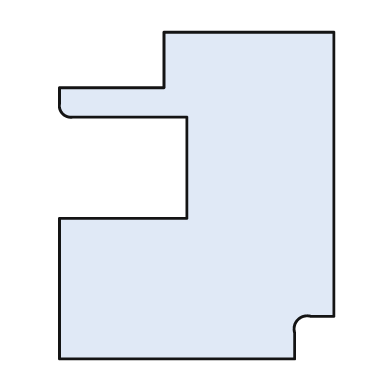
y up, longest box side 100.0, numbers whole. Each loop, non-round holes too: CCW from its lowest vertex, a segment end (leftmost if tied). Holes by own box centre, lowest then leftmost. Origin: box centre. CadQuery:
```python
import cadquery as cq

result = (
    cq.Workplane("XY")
    .moveTo(-42.0, -50.0)
    .lineTo(30.0, -50.0)
    .lineTo(30.0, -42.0)
    .threePointArc((31.0, -38.0), (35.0, -37.0))
    .lineTo(42.0, -37.0)
    .lineTo(42.0, 50.0)
    .lineTo(-10.0, 50.0)
    .lineTo(-10.0, 33.0)
    .lineTo(-42.0, 33.0)
    .lineTo(-42.0, 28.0)
    .threePointArc((-41.0, 25.0), (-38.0, 24.0))
    .lineTo(-3.0, 24.0)
    .lineTo(-3.0, -7.0)
    .lineTo(-42.0, -7.0)
    .close()
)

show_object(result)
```